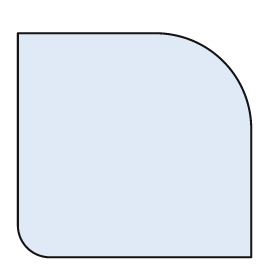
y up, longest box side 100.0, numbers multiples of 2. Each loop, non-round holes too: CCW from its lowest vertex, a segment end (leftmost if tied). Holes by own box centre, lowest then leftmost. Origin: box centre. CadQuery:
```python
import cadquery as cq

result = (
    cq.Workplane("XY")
    .moveTo(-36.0, -48.0)
    .lineTo(50.0, -48.0)
    .lineTo(50.0, 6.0)
    .threePointArc((38.0, 36.0), (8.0, 48.0))
    .lineTo(-50.0, 48.0)
    .lineTo(-50.0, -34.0)
    .threePointArc((-46.0, -44.0), (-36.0, -48.0))
    .close()
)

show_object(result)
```